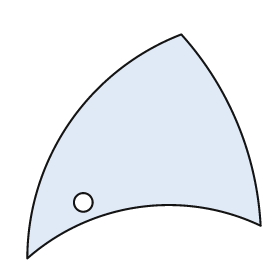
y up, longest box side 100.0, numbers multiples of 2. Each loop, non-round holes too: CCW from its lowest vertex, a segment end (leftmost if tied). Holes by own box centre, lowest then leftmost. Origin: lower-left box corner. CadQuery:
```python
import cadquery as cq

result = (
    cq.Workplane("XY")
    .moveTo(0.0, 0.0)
    .threePointArc((48.0, 22.0), (100.0, 14.0))
    .threePointArc((90.0, 58.0), (66.0, 96.0))
    .threePointArc((18.0, 58.0), (0.0, 0.0))
    .close()
    .moveTo(24.0, 24.0)
    .circle(4.0)
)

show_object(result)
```